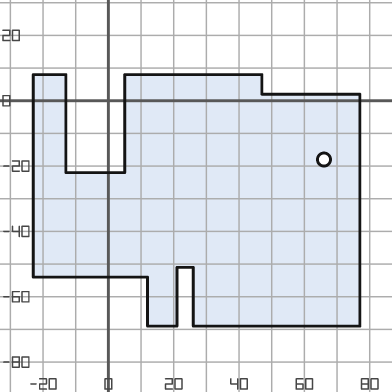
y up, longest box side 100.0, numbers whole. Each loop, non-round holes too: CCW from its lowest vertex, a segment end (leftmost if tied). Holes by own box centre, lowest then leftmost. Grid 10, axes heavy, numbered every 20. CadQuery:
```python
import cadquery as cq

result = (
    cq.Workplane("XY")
    .moveTo(12.0, -69.0)
    .lineTo(21.0, -69.0)
    .lineTo(21.0, -51.0)
    .lineTo(26.0, -51.0)
    .lineTo(26.0, -69.0)
    .lineTo(77.0, -69.0)
    .lineTo(77.0, 2.0)
    .lineTo(47.0, 2.0)
    .lineTo(47.0, 8.0)
    .lineTo(5.0, 8.0)
    .lineTo(5.0, -22.0)
    .lineTo(-13.0, -22.0)
    .lineTo(-13.0, 8.0)
    .lineTo(-23.0, 8.0)
    .lineTo(-23.0, -54.0)
    .lineTo(12.0, -54.0)
    .close()
    .moveTo(66.0, -18.0)
    .circle(2.0)
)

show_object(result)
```